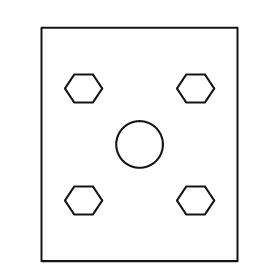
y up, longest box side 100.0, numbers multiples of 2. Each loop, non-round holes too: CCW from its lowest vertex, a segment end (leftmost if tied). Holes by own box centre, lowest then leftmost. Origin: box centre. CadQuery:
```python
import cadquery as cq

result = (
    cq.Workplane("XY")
    .moveTo(-42.0, -50.0)
    .lineTo(42.0, -50.0)
    .lineTo(42.0, 50.0)
    .lineTo(-42.0, 50.0)
    .close()
    .moveTo(-28.0, -30.0)
    .lineTo(-20.0, -30.0)
    .lineTo(-16.0, -24.0)
    .lineTo(-20.0, -18.0)
    .lineTo(-28.0, -18.0)
    .lineTo(-32.0, -24.0)
    .close()
    .moveTo(20.0, -30.0)
    .lineTo(28.0, -30.0)
    .lineTo(32.0, -24.0)
    .lineTo(28.0, -18.0)
    .lineTo(20.0, -18.0)
    .lineTo(16.0, -24.0)
    .close()
    .moveTo(0.0, 0.0)
    .circle(10.0)
    .moveTo(-28.0, 18.0)
    .lineTo(-20.0, 18.0)
    .lineTo(-16.0, 24.0)
    .lineTo(-20.0, 30.0)
    .lineTo(-28.0, 30.0)
    .lineTo(-32.0, 24.0)
    .close()
    .moveTo(20.0, 18.0)
    .lineTo(28.0, 18.0)
    .lineTo(32.0, 24.0)
    .lineTo(28.0, 30.0)
    .lineTo(20.0, 30.0)
    .lineTo(16.0, 24.0)
    .close()
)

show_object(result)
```